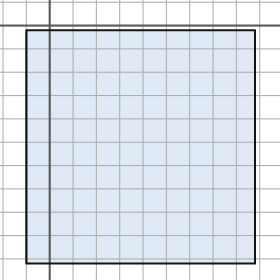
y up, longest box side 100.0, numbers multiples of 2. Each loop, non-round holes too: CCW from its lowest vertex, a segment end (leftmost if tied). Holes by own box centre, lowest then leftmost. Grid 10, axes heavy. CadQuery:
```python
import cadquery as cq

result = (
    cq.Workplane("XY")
    .moveTo(-10.0, -102.0)
    .lineTo(88.0, -102.0)
    .lineTo(88.0, -2.0)
    .lineTo(-10.0, -2.0)
    .close()
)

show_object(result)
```